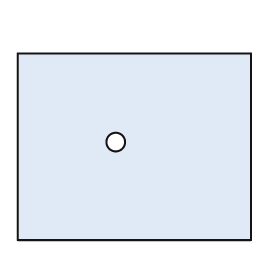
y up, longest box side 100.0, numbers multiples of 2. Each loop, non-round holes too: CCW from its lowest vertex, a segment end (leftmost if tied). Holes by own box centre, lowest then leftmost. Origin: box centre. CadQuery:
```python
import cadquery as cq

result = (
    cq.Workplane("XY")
    .moveTo(-50.0, -40.0)
    .lineTo(50.0, -40.0)
    .lineTo(50.0, 40.0)
    .lineTo(-50.0, 40.0)
    .close()
    .moveTo(-8.0, 2.0)
    .circle(4.0)
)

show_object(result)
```